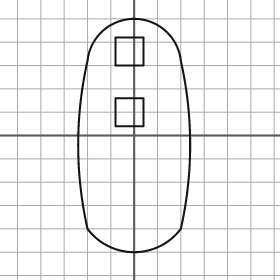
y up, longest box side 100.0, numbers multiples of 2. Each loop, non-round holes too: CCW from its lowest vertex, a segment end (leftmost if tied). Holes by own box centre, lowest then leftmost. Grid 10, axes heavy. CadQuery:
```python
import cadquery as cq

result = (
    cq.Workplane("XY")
    .moveTo(-20.0, -40.0)
    .threePointArc((0.0, -50.0), (20.0, -40.0))
    .threePointArc((24.0, -4.0), (20.0, 32.0))
    .threePointArc((0.0, 50.0), (-20.0, 32.0))
    .threePointArc((-24.0, -4.0), (-20.0, -40.0))
    .close()
    .moveTo(-8.0, 4.0)
    .lineTo(4.0, 4.0)
    .lineTo(4.0, 16.0)
    .lineTo(-8.0, 16.0)
    .close()
    .moveTo(-8.0, 30.0)
    .lineTo(4.0, 30.0)
    .lineTo(4.0, 42.0)
    .lineTo(-8.0, 42.0)
    .close()
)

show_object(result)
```